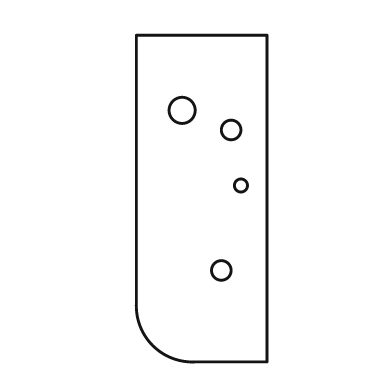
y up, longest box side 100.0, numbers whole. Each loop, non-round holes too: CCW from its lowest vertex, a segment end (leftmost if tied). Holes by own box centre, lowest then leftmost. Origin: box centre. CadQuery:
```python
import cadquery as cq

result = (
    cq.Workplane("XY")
    .moveTo(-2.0, -50.0)
    .lineTo(20.0, -50.0)
    .lineTo(20.0, 50.0)
    .lineTo(-20.0, 50.0)
    .lineTo(-20.0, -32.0)
    .threePointArc((-15.0, -45.0), (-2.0, -50.0))
    .close()
    .moveTo(6.0, -22.0)
    .circle(3.0)
    .moveTo(12.0, 4.0)
    .circle(2.0)
    .moveTo(9.0, 21.0)
    .circle(3.0)
    .moveTo(-6.0, 27.0)
    .circle(4.0)
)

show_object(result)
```